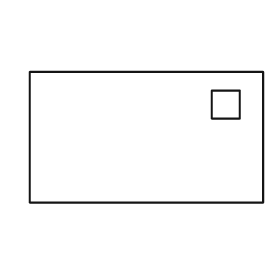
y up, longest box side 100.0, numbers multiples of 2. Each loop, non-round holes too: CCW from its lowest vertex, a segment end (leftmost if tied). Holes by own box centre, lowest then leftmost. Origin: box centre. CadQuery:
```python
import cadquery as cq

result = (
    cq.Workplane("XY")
    .moveTo(-50.0, -28.0)
    .lineTo(50.0, -28.0)
    .lineTo(50.0, 28.0)
    .lineTo(-50.0, 28.0)
    .close()
    .moveTo(28.0, 8.0)
    .lineTo(40.0, 8.0)
    .lineTo(40.0, 20.0)
    .lineTo(28.0, 20.0)
    .close()
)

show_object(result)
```